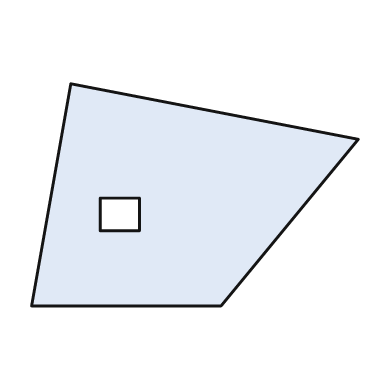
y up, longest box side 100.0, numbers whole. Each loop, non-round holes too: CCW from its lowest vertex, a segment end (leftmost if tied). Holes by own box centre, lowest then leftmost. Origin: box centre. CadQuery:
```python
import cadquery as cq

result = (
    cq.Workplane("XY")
    .moveTo(-50.0, -34.0)
    .lineTo(8.0, -34.0)
    .lineTo(50.0, 17.0)
    .lineTo(-38.0, 34.0)
    .close()
    .moveTo(-29.0, -11.0)
    .lineTo(-17.0, -11.0)
    .lineTo(-17.0, -1.0)
    .lineTo(-29.0, -1.0)
    .close()
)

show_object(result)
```